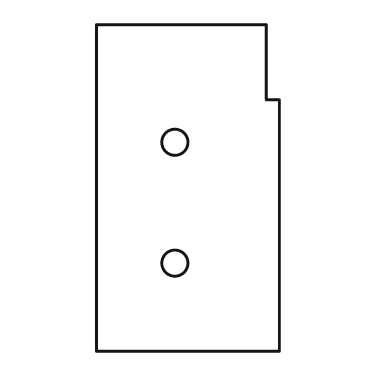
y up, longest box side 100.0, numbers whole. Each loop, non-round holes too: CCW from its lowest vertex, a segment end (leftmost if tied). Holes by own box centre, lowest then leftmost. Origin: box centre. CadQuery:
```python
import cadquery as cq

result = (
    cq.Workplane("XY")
    .moveTo(-28.0, -50.0)
    .lineTo(28.0, -50.0)
    .lineTo(28.0, 27.0)
    .lineTo(24.0, 27.0)
    .lineTo(24.0, 50.0)
    .lineTo(-28.0, 50.0)
    .close()
    .moveTo(-4.0, -23.0)
    .circle(4.0)
    .moveTo(-4.0, 14.0)
    .circle(4.0)
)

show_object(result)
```